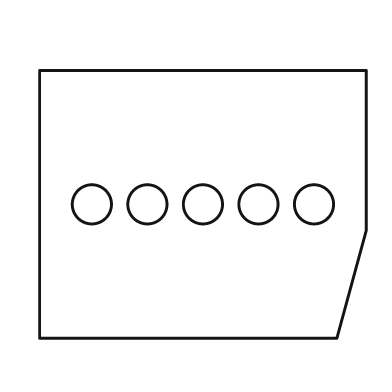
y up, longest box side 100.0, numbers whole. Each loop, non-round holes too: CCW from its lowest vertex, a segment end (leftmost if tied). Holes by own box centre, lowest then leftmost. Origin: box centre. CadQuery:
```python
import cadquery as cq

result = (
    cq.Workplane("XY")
    .moveTo(-50.0, -41.0)
    .lineTo(41.0, -41.0)
    .lineTo(50.0, -8.0)
    .lineTo(50.0, 41.0)
    .lineTo(-50.0, 41.0)
    .close()
    .moveTo(-34.0, 0.0)
    .circle(6.0)
    .moveTo(-17.0, 0.0)
    .circle(6.0)
    .moveTo(0.0, 0.0)
    .circle(6.0)
    .moveTo(17.0, 0.0)
    .circle(6.0)
    .moveTo(34.0, 0.0)
    .circle(6.0)
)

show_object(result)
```